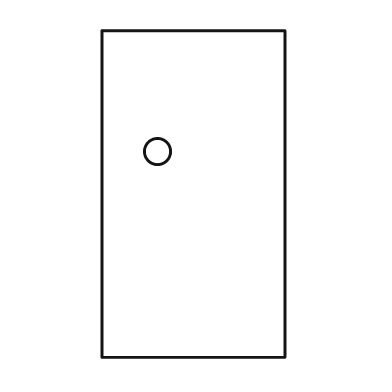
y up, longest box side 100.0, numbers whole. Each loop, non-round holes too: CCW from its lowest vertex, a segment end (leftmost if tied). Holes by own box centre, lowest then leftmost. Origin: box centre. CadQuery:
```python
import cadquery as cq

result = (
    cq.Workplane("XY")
    .moveTo(-28.0, -50.0)
    .lineTo(28.0, -50.0)
    .lineTo(28.0, 50.0)
    .lineTo(-28.0, 50.0)
    .close()
    .moveTo(-11.0, 13.0)
    .circle(4.0)
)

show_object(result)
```